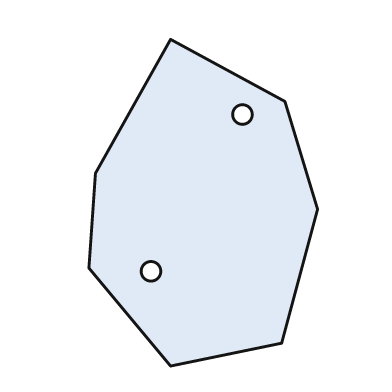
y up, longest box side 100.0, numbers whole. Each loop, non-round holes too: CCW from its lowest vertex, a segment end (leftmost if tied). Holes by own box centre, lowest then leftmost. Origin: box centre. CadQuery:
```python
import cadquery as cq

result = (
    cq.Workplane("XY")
    .moveTo(-10.0, -50.0)
    .lineTo(24.0, -43.0)
    .lineTo(35.0, -2.0)
    .lineTo(25.0, 31.0)
    .lineTo(-10.0, 50.0)
    .lineTo(-33.0, 9.0)
    .lineTo(-35.0, -20.0)
    .close()
    .moveTo(-16.0, -21.0)
    .circle(3.0)
    .moveTo(12.0, 27.0)
    .circle(3.0)
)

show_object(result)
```